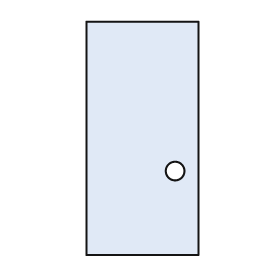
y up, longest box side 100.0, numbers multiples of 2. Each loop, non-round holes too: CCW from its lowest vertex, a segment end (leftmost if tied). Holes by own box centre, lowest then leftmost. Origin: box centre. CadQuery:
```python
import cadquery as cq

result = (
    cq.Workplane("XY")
    .moveTo(-24.0, -50.0)
    .lineTo(24.0, -50.0)
    .lineTo(24.0, 50.0)
    .lineTo(-24.0, 50.0)
    .close()
    .moveTo(14.0, -14.0)
    .circle(4.0)
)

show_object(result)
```